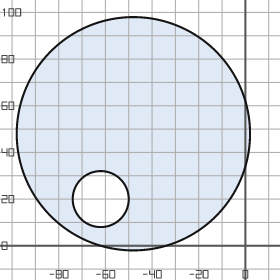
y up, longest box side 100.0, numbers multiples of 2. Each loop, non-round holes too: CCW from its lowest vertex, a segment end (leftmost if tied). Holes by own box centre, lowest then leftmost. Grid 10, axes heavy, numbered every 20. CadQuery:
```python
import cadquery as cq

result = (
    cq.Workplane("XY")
    .moveTo(-48.0, 48.0)
    .circle(50.0)
    .moveTo(-62.0, 20.0)
    .circle(12.0)
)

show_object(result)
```